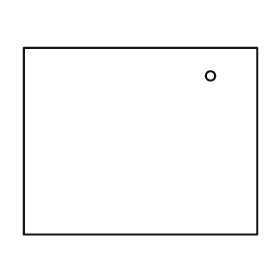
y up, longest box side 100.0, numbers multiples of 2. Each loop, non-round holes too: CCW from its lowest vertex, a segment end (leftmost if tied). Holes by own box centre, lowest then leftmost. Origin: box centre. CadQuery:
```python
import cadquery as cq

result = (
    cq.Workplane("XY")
    .moveTo(-50.0, -40.0)
    .lineTo(50.0, -40.0)
    .lineTo(50.0, 40.0)
    .lineTo(-50.0, 40.0)
    .close()
    .moveTo(30.0, 28.0)
    .circle(2.0)
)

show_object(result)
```